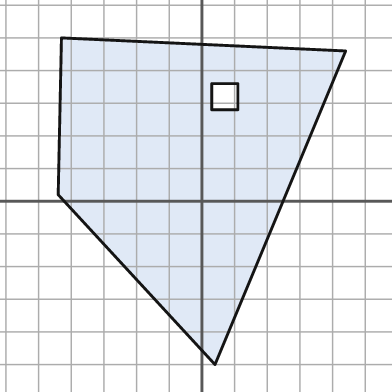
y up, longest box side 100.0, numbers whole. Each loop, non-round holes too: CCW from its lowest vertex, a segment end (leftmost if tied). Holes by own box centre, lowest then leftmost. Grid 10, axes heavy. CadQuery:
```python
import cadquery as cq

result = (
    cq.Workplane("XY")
    .moveTo(4.0, -50.0)
    .lineTo(44.0, 46.0)
    .lineTo(-43.0, 50.0)
    .lineTo(-44.0, 2.0)
    .close()
    .moveTo(3.0, 28.0)
    .lineTo(11.0, 28.0)
    .lineTo(11.0, 36.0)
    .lineTo(3.0, 36.0)
    .close()
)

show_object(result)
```